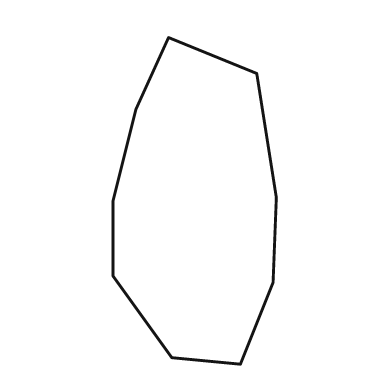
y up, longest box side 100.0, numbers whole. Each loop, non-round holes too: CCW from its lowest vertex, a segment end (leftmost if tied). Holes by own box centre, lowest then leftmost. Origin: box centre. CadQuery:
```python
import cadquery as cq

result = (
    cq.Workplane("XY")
    .moveTo(14.0, -50.0)
    .lineTo(24.0, -25.0)
    .lineTo(25.0, 1.0)
    .lineTo(19.0, 39.0)
    .lineTo(-8.0, 50.0)
    .lineTo(-18.0, 28.0)
    .lineTo(-25.0, 0.0)
    .lineTo(-25.0, -23.0)
    .lineTo(-7.0, -48.0)
    .close()
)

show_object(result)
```